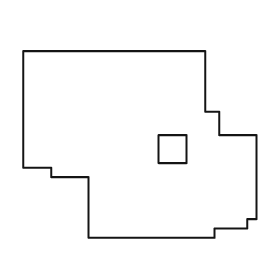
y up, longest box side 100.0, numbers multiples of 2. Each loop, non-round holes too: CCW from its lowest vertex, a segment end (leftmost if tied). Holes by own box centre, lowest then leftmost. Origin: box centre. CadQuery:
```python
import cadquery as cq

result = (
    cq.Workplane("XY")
    .moveTo(-22.0, -40.0)
    .lineTo(32.0, -40.0)
    .lineTo(32.0, -36.0)
    .lineTo(46.0, -36.0)
    .lineTo(46.0, -32.0)
    .lineTo(50.0, -32.0)
    .lineTo(50.0, 4.0)
    .lineTo(34.0, 4.0)
    .lineTo(34.0, 14.0)
    .lineTo(28.0, 14.0)
    .lineTo(28.0, 40.0)
    .lineTo(-50.0, 40.0)
    .lineTo(-50.0, -10.0)
    .lineTo(-38.0, -10.0)
    .lineTo(-38.0, -14.0)
    .lineTo(-22.0, -14.0)
    .close()
    .moveTo(8.0, -8.0)
    .lineTo(20.0, -8.0)
    .lineTo(20.0, 4.0)
    .lineTo(8.0, 4.0)
    .close()
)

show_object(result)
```